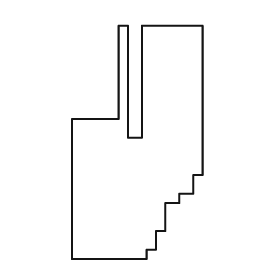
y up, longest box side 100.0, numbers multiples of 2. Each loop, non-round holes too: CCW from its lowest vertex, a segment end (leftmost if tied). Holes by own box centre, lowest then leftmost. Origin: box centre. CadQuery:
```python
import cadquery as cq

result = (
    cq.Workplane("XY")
    .moveTo(-28.0, -50.0)
    .lineTo(4.0, -50.0)
    .lineTo(4.0, -46.0)
    .lineTo(8.0, -46.0)
    .lineTo(8.0, -38.0)
    .lineTo(12.0, -38.0)
    .lineTo(12.0, -26.0)
    .lineTo(18.0, -26.0)
    .lineTo(18.0, -22.0)
    .lineTo(24.0, -22.0)
    .lineTo(24.0, -14.0)
    .lineTo(28.0, -14.0)
    .lineTo(28.0, 50.0)
    .lineTo(2.0, 50.0)
    .lineTo(2.0, 2.0)
    .lineTo(-4.0, 2.0)
    .lineTo(-4.0, 50.0)
    .lineTo(-8.0, 50.0)
    .lineTo(-8.0, 10.0)
    .lineTo(-28.0, 10.0)
    .close()
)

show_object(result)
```